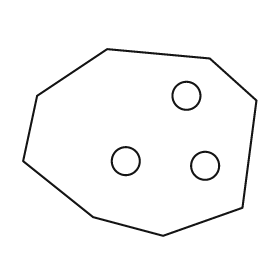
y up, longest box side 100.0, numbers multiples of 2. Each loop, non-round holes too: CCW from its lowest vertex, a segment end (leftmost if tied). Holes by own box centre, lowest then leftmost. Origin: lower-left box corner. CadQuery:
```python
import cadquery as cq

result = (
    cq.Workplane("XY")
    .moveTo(60.0, 0.0)
    .lineTo(94.0, 12.0)
    .lineTo(100.0, 58.0)
    .lineTo(80.0, 76.0)
    .lineTo(36.0, 80.0)
    .lineTo(6.0, 60.0)
    .lineTo(0.0, 32.0)
    .lineTo(30.0, 8.0)
    .close()
    .moveTo(78.0, 30.0)
    .circle(6.0)
    .moveTo(44.0, 32.0)
    .circle(6.0)
    .moveTo(70.0, 60.0)
    .circle(6.0)
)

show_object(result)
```